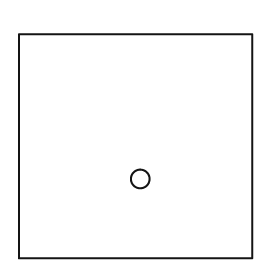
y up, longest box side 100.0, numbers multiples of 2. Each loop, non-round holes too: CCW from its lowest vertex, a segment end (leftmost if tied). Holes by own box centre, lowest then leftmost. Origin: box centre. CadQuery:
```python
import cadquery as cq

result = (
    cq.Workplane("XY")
    .moveTo(-50.0, -48.0)
    .lineTo(50.0, -48.0)
    .lineTo(50.0, 48.0)
    .lineTo(-50.0, 48.0)
    .close()
    .moveTo(2.0, -14.0)
    .circle(4.0)
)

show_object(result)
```